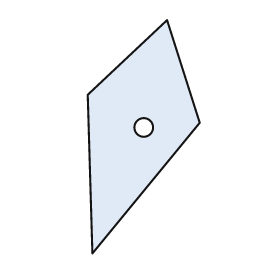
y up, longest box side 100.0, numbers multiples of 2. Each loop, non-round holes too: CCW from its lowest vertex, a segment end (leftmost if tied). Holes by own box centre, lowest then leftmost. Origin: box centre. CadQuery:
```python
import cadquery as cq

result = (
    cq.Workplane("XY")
    .moveTo(-22.0, -50.0)
    .lineTo(24.0, 6.0)
    .lineTo(10.0, 50.0)
    .lineTo(-24.0, 18.0)
    .close()
    .moveTo(0.0, 4.0)
    .circle(4.0)
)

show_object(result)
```